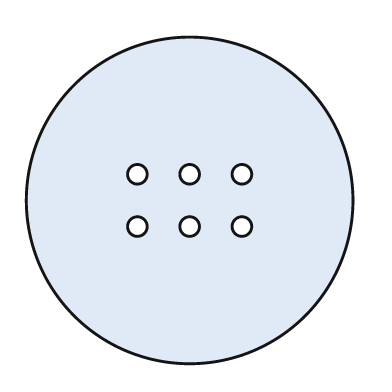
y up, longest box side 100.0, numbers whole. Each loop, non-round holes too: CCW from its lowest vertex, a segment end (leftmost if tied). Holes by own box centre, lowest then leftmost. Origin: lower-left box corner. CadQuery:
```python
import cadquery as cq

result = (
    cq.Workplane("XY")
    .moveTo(50.0, 50.0)
    .circle(50.0)
    .moveTo(34.0, 42.0)
    .circle(3.0)
    .moveTo(50.0, 42.0)
    .circle(3.0)
    .moveTo(66.0, 42.0)
    .circle(3.0)
    .moveTo(34.0, 58.0)
    .circle(3.0)
    .moveTo(50.0, 58.0)
    .circle(3.0)
    .moveTo(66.0, 58.0)
    .circle(3.0)
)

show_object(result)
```